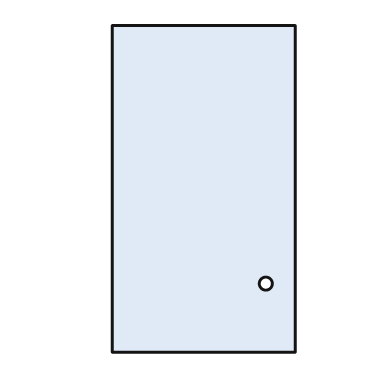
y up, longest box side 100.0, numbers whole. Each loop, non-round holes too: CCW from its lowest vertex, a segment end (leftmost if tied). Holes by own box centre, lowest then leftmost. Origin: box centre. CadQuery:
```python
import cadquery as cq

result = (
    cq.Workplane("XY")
    .moveTo(-28.0, -50.0)
    .lineTo(28.0, -50.0)
    .lineTo(28.0, 50.0)
    .lineTo(-28.0, 50.0)
    .close()
    .moveTo(19.0, -29.0)
    .circle(2.0)
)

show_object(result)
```